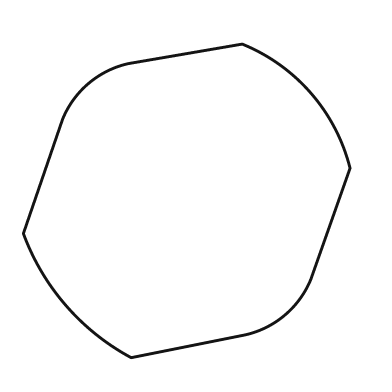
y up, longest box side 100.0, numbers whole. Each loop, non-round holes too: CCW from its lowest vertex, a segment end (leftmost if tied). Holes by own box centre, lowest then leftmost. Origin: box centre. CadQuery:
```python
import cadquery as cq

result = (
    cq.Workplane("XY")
    .moveTo(-17.0, -48.0)
    .lineTo(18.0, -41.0)
    .threePointArc((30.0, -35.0), (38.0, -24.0))
    .lineTo(50.0, 10.0)
    .threePointArc((38.0, 33.0), (17.0, 48.0))
    .lineTo(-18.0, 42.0)
    .threePointArc((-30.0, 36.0), (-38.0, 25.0))
    .lineTo(-50.0, -10.0)
    .threePointArc((-37.0, -32.0), (-17.0, -48.0))
    .close()
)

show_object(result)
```